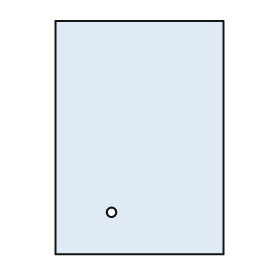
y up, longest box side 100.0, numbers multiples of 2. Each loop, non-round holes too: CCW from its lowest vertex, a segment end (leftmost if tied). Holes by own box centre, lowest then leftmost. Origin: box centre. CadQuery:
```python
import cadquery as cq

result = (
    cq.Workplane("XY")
    .moveTo(-36.0, -50.0)
    .lineTo(36.0, -50.0)
    .lineTo(36.0, 50.0)
    .lineTo(-36.0, 50.0)
    .close()
    .moveTo(-12.0, -32.0)
    .circle(2.0)
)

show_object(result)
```